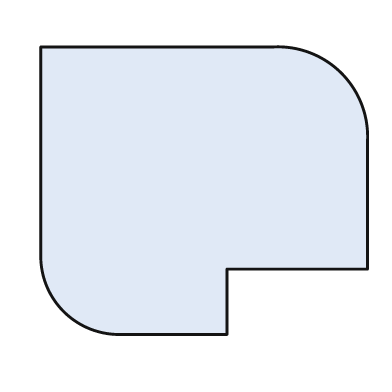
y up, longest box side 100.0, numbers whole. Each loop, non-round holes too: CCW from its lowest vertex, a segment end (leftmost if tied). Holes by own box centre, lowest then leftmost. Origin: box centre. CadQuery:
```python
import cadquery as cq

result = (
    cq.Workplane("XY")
    .moveTo(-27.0, -44.0)
    .lineTo(7.0, -44.0)
    .lineTo(7.0, -24.0)
    .lineTo(50.0, -24.0)
    .lineTo(50.0, 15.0)
    .threePointArc((42.0, 36.0), (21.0, 44.0))
    .lineTo(-50.0, 44.0)
    .lineTo(-50.0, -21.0)
    .threePointArc((-43.0, -37.0), (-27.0, -44.0))
    .close()
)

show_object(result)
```